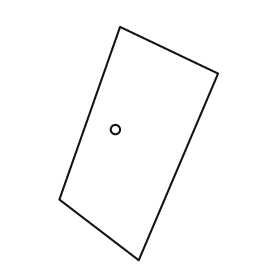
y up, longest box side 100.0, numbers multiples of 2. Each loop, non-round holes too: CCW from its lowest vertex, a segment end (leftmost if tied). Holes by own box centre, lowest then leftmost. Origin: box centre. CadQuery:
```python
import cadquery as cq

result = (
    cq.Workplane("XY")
    .moveTo(0.0, -50.0)
    .lineTo(34.0, 30.0)
    .lineTo(-8.0, 50.0)
    .lineTo(-34.0, -24.0)
    .close()
    .moveTo(-10.0, 6.0)
    .circle(2.0)
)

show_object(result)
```